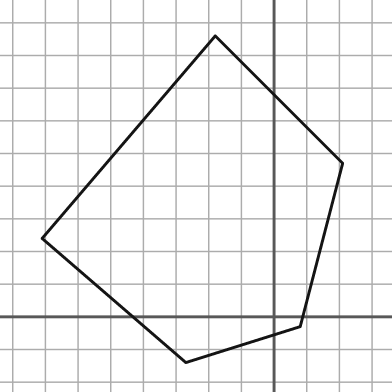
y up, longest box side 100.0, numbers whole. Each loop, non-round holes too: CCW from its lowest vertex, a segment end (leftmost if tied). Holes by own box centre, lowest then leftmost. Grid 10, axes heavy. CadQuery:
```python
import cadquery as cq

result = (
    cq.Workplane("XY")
    .moveTo(-27.0, -14.0)
    .lineTo(8.0, -3.0)
    .lineTo(21.0, 47.0)
    .lineTo(-18.0, 86.0)
    .lineTo(-71.0, 24.0)
    .close()
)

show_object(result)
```